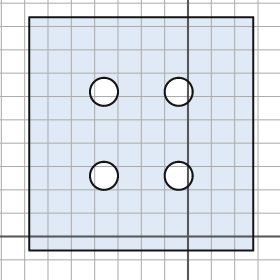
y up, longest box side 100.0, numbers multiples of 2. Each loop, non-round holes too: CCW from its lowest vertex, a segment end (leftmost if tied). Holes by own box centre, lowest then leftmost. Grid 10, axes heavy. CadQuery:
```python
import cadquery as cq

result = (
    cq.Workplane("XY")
    .moveTo(-68.0, -6.0)
    .lineTo(28.0, -6.0)
    .lineTo(28.0, 94.0)
    .lineTo(-68.0, 94.0)
    .close()
    .moveTo(-36.0, 26.0)
    .circle(6.0)
    .moveTo(-4.0, 26.0)
    .circle(6.0)
    .moveTo(-36.0, 62.0)
    .circle(6.0)
    .moveTo(-4.0, 62.0)
    .circle(6.0)
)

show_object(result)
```